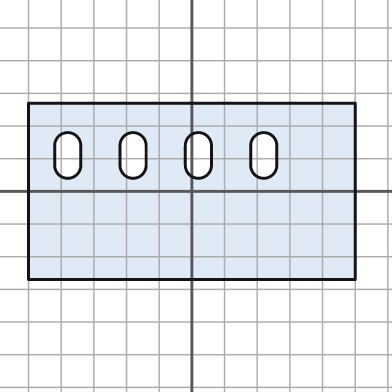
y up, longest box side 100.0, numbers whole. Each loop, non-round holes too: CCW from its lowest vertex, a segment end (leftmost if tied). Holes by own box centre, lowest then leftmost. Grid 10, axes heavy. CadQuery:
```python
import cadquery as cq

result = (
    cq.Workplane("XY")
    .moveTo(-50.0, -27.0)
    .lineTo(50.0, -27.0)
    .lineTo(50.0, 27.0)
    .lineTo(-50.0, 27.0)
    .close()
    .moveTo(-42.0, 8.0)
    .threePointArc((-38.0, 4.0), (-34.0, 8.0))
    .lineTo(-34.0, 14.0)
    .threePointArc((-38.0, 18.0), (-42.0, 14.0))
    .close()
    .moveTo(-22.0, 8.0)
    .threePointArc((-18.0, 4.0), (-14.0, 8.0))
    .lineTo(-14.0, 14.0)
    .threePointArc((-18.0, 18.0), (-22.0, 14.0))
    .close()
    .moveTo(-2.0, 8.0)
    .threePointArc((2.0, 4.0), (6.0, 8.0))
    .lineTo(6.0, 14.0)
    .threePointArc((2.0, 18.0), (-2.0, 14.0))
    .close()
    .moveTo(18.0, 8.0)
    .threePointArc((22.0, 4.0), (26.0, 8.0))
    .lineTo(26.0, 14.0)
    .threePointArc((22.0, 18.0), (18.0, 14.0))
    .close()
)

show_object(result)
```